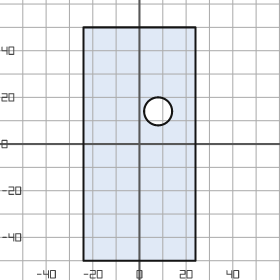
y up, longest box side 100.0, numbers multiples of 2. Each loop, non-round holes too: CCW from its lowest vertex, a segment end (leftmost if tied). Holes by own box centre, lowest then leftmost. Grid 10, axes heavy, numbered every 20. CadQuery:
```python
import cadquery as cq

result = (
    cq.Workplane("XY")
    .moveTo(-24.0, -50.0)
    .lineTo(24.0, -50.0)
    .lineTo(24.0, 50.0)
    .lineTo(-24.0, 50.0)
    .close()
    .moveTo(8.0, 14.0)
    .circle(6.0)
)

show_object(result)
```